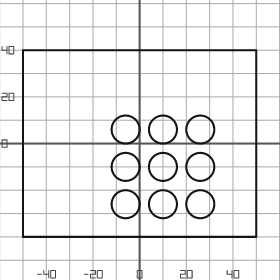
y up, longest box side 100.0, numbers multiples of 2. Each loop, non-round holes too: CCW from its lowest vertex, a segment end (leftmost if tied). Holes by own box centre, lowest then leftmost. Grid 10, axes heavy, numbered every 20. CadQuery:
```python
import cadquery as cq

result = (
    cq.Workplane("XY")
    .moveTo(-50.0, -40.0)
    .lineTo(50.0, -40.0)
    .lineTo(50.0, 40.0)
    .lineTo(-50.0, 40.0)
    .close()
    .moveTo(-6.0, -26.0)
    .circle(6.0)
    .moveTo(10.0, -26.0)
    .circle(6.0)
    .moveTo(26.0, -26.0)
    .circle(6.0)
    .moveTo(-6.0, -10.0)
    .circle(6.0)
    .moveTo(10.0, -10.0)
    .circle(6.0)
    .moveTo(26.0, -10.0)
    .circle(6.0)
    .moveTo(-6.0, 6.0)
    .circle(6.0)
    .moveTo(10.0, 6.0)
    .circle(6.0)
    .moveTo(26.0, 6.0)
    .circle(6.0)
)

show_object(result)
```